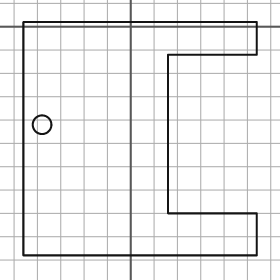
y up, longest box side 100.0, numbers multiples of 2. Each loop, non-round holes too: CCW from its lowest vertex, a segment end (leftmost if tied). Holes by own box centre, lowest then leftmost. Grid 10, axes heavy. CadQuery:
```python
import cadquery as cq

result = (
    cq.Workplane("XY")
    .moveTo(-46.0, -98.0)
    .lineTo(54.0, -98.0)
    .lineTo(54.0, -80.0)
    .lineTo(16.0, -80.0)
    .lineTo(16.0, -12.0)
    .lineTo(54.0, -12.0)
    .lineTo(54.0, 2.0)
    .lineTo(-46.0, 2.0)
    .close()
    .moveTo(-38.0, -42.0)
    .circle(4.0)
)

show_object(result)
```